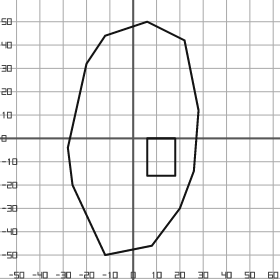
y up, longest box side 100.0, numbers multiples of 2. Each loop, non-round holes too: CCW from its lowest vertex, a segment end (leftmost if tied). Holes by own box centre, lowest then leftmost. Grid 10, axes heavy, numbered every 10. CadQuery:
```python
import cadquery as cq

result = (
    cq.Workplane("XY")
    .moveTo(-12.0, -50.0)
    .lineTo(8.0, -46.0)
    .lineTo(20.0, -30.0)
    .lineTo(26.0, -14.0)
    .lineTo(28.0, 12.0)
    .lineTo(22.0, 42.0)
    .lineTo(6.0, 50.0)
    .lineTo(-12.0, 44.0)
    .lineTo(-20.0, 32.0)
    .lineTo(-28.0, -4.0)
    .lineTo(-26.0, -20.0)
    .close()
    .moveTo(6.0, -16.0)
    .lineTo(18.0, -16.0)
    .lineTo(18.0, 0.0)
    .lineTo(6.0, 0.0)
    .close()
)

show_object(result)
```